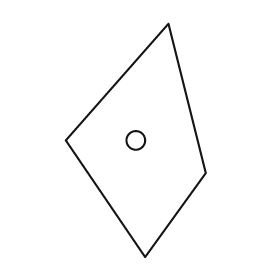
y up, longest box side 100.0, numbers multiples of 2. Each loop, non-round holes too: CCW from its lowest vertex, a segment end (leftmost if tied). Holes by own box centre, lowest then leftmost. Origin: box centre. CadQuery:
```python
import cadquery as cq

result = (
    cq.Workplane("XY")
    .moveTo(4.0, -50.0)
    .lineTo(30.0, -14.0)
    .lineTo(14.0, 50.0)
    .lineTo(-30.0, 0.0)
    .close()
    .moveTo(0.0, 0.0)
    .circle(4.0)
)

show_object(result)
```